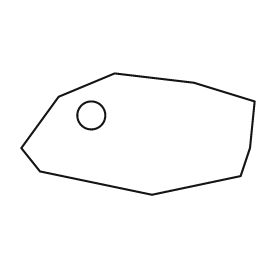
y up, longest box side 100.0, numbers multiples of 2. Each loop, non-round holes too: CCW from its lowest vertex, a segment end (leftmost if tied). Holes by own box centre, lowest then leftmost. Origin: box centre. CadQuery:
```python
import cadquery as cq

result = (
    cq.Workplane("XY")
    .moveTo(6.0, -26.0)
    .lineTo(44.0, -18.0)
    .lineTo(48.0, -6.0)
    .lineTo(50.0, 14.0)
    .lineTo(24.0, 22.0)
    .lineTo(-10.0, 26.0)
    .lineTo(-34.0, 16.0)
    .lineTo(-50.0, -6.0)
    .lineTo(-42.0, -16.0)
    .close()
    .moveTo(-20.0, 8.0)
    .circle(6.0)
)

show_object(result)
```